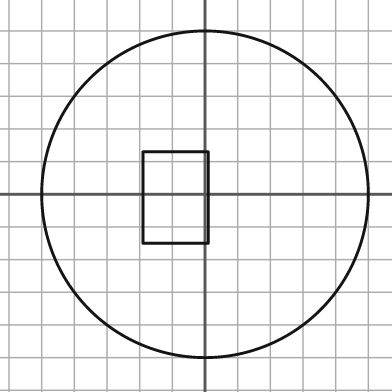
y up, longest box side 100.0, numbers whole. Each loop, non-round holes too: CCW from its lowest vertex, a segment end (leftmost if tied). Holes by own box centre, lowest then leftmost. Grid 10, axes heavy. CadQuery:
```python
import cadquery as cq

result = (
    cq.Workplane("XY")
    .moveTo(0.0, 0.0)
    .circle(50.0)
    .moveTo(-19.0, -15.0)
    .lineTo(1.0, -15.0)
    .lineTo(1.0, 13.0)
    .lineTo(-19.0, 13.0)
    .close()
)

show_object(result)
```